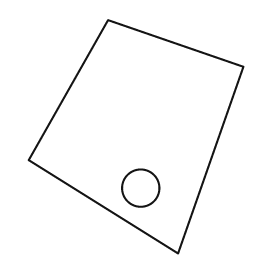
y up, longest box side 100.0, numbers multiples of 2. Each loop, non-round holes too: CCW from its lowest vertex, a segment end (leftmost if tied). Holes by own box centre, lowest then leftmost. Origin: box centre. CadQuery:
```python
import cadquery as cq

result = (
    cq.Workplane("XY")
    .moveTo(18.0, -50.0)
    .lineTo(46.0, 30.0)
    .lineTo(-12.0, 50.0)
    .lineTo(-46.0, -10.0)
    .close()
    .moveTo(2.0, -22.0)
    .circle(8.0)
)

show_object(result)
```